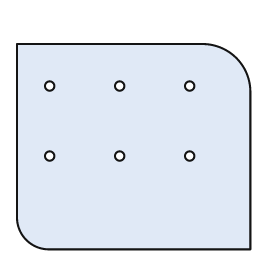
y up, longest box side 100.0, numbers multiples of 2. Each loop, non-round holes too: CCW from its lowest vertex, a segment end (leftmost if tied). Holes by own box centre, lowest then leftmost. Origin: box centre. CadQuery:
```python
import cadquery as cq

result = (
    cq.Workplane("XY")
    .moveTo(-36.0, -44.0)
    .lineTo(50.0, -44.0)
    .lineTo(50.0, 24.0)
    .threePointArc((44.0, 38.0), (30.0, 44.0))
    .lineTo(-50.0, 44.0)
    .lineTo(-50.0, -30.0)
    .threePointArc((-46.0, -40.0), (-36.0, -44.0))
    .close()
    .moveTo(-36.0, -4.0)
    .circle(2.0)
    .moveTo(-6.0, -4.0)
    .circle(2.0)
    .moveTo(24.0, -4.0)
    .circle(2.0)
    .moveTo(-36.0, 26.0)
    .circle(2.0)
    .moveTo(-6.0, 26.0)
    .circle(2.0)
    .moveTo(24.0, 26.0)
    .circle(2.0)
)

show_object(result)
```